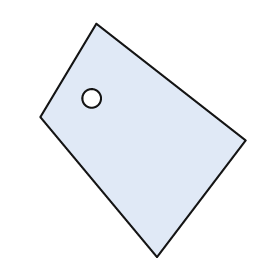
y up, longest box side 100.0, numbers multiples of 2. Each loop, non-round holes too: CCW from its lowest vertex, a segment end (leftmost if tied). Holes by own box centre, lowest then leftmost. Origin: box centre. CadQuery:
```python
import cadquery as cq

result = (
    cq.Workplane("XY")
    .moveTo(6.0, -50.0)
    .lineTo(44.0, 0.0)
    .lineTo(-20.0, 50.0)
    .lineTo(-44.0, 10.0)
    .close()
    .moveTo(-22.0, 18.0)
    .circle(4.0)
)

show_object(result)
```